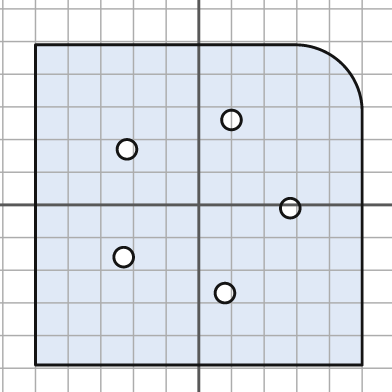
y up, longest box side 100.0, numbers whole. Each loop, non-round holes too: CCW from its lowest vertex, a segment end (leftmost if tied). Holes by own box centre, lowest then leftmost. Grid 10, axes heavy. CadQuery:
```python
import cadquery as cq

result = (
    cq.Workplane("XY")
    .moveTo(-50.0, -49.0)
    .lineTo(50.0, -49.0)
    .lineTo(50.0, 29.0)
    .threePointArc((44.0, 43.0), (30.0, 49.0))
    .lineTo(-50.0, 49.0)
    .close()
    .moveTo(8.0, -27.0)
    .circle(3.0)
    .moveTo(-23.0, -16.0)
    .circle(3.0)
    .moveTo(28.0, -1.0)
    .circle(3.0)
    .moveTo(-22.0, 17.0)
    .circle(3.0)
    .moveTo(10.0, 26.0)
    .circle(3.0)
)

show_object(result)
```